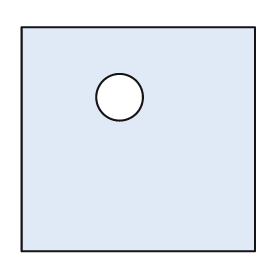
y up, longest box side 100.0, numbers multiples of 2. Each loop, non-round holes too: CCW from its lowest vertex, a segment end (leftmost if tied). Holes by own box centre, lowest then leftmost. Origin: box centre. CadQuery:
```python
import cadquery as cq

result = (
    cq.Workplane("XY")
    .moveTo(-50.0, -48.0)
    .lineTo(50.0, -48.0)
    .lineTo(50.0, 48.0)
    .lineTo(-50.0, 48.0)
    .close()
    .moveTo(-8.0, 18.0)
    .circle(10.0)
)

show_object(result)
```